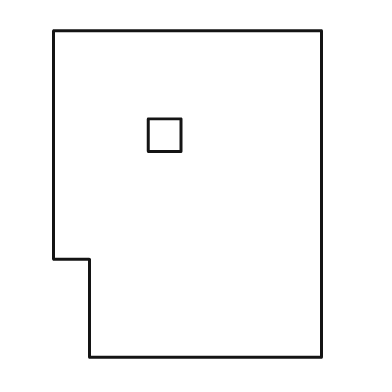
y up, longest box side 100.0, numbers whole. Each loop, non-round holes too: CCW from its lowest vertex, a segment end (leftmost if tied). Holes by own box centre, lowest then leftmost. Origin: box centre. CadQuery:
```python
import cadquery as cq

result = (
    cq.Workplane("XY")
    .moveTo(-30.0, -50.0)
    .lineTo(41.0, -50.0)
    .lineTo(41.0, 50.0)
    .lineTo(-41.0, 50.0)
    .lineTo(-41.0, -20.0)
    .lineTo(-30.0, -20.0)
    .close()
    .moveTo(-12.0, 13.0)
    .lineTo(-2.0, 13.0)
    .lineTo(-2.0, 23.0)
    .lineTo(-12.0, 23.0)
    .close()
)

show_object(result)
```